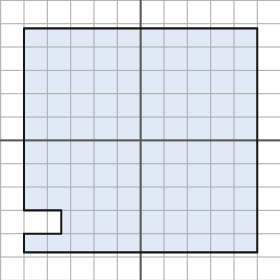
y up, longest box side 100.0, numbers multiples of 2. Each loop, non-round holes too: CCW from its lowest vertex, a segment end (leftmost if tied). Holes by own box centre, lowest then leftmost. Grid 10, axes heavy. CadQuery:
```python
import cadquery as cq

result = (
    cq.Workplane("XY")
    .moveTo(-50.0, -48.0)
    .lineTo(50.0, -48.0)
    .lineTo(50.0, 48.0)
    .lineTo(-50.0, 48.0)
    .lineTo(-50.0, -30.0)
    .lineTo(-34.0, -30.0)
    .lineTo(-34.0, -40.0)
    .lineTo(-50.0, -40.0)
    .close()
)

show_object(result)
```